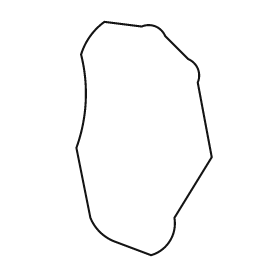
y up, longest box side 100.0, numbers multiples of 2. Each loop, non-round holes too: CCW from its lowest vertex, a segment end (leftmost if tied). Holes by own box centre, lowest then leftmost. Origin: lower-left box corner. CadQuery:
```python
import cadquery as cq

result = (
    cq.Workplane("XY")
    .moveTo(32.0, 0.0)
    .threePointArc((40.0, 6.0), (42.0, 16.0))
    .lineTo(58.0, 42.0)
    .lineTo(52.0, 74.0)
    .threePointArc((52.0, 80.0), (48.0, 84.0))
    .lineTo(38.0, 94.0)
    .threePointArc((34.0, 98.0), (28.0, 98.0))
    .lineTo(12.0, 100.0)
    .threePointArc((6.0, 94.0), (2.0, 86.0))
    .threePointArc((4.0, 66.0), (0.0, 46.0))
    .lineTo(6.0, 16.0)
    .threePointArc((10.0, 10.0), (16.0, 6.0))
    .close()
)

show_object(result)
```